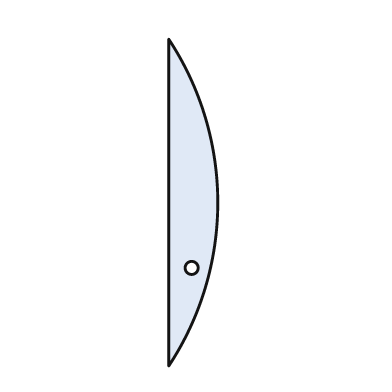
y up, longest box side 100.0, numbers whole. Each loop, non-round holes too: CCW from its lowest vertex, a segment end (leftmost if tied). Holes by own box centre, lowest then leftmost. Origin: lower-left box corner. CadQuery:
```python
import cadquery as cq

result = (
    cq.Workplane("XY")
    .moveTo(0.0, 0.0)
    .threePointArc((15.0, 50.0), (0.0, 100.0))
    .close()
    .moveTo(7.0, 30.0)
    .circle(2.0)
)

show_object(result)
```